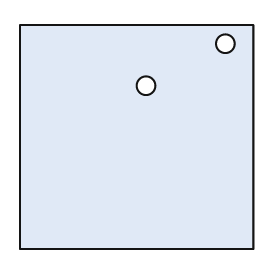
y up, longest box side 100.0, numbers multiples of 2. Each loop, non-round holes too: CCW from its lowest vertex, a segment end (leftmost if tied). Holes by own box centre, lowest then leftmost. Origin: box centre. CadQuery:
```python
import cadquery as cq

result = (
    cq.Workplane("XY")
    .moveTo(-50.0, -48.0)
    .lineTo(50.0, -48.0)
    .lineTo(50.0, 48.0)
    .lineTo(-50.0, 48.0)
    .close()
    .moveTo(4.0, 22.0)
    .circle(4.0)
    .moveTo(38.0, 40.0)
    .circle(4.0)
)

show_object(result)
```